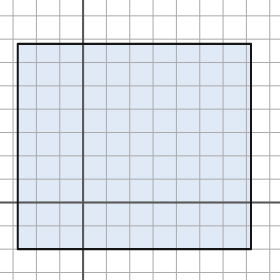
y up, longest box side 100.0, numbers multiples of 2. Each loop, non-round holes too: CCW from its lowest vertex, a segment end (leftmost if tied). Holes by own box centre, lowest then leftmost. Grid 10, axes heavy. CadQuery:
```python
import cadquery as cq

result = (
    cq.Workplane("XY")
    .moveTo(-28.0, -20.0)
    .lineTo(72.0, -20.0)
    .lineTo(72.0, 68.0)
    .lineTo(-28.0, 68.0)
    .close()
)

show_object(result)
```